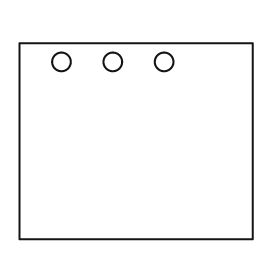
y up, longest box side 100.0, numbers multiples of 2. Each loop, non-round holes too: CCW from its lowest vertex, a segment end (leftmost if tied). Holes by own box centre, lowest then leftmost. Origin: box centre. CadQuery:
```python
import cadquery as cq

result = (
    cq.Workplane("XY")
    .moveTo(-50.0, -42.0)
    .lineTo(50.0, -42.0)
    .lineTo(50.0, 42.0)
    .lineTo(-50.0, 42.0)
    .close()
    .moveTo(-32.0, 34.0)
    .circle(4.0)
    .moveTo(-10.0, 34.0)
    .circle(4.0)
    .moveTo(12.0, 34.0)
    .circle(4.0)
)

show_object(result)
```